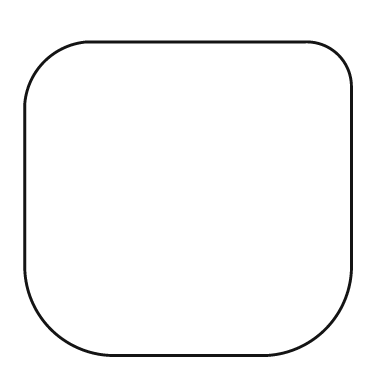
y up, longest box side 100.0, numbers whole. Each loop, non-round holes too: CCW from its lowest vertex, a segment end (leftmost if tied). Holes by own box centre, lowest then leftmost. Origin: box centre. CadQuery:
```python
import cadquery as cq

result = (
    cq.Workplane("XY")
    .moveTo(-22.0, -48.0)
    .lineTo(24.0, -48.0)
    .threePointArc((42.0, -40.0), (50.0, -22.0))
    .lineTo(50.0, 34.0)
    .threePointArc((46.0, 44.0), (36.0, 48.0))
    .lineTo(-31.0, 48.0)
    .threePointArc((-44.0, 42.0), (-50.0, 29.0))
    .lineTo(-50.0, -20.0)
    .threePointArc((-42.0, -40.0), (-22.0, -48.0))
    .close()
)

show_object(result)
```